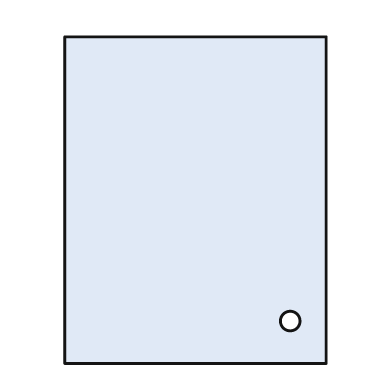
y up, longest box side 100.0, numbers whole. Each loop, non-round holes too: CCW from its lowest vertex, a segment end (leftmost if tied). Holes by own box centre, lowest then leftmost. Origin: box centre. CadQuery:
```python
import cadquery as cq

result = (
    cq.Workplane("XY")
    .moveTo(-40.0, -50.0)
    .lineTo(40.0, -50.0)
    .lineTo(40.0, 50.0)
    .lineTo(-40.0, 50.0)
    .close()
    .moveTo(29.0, -37.0)
    .circle(3.0)
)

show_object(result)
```